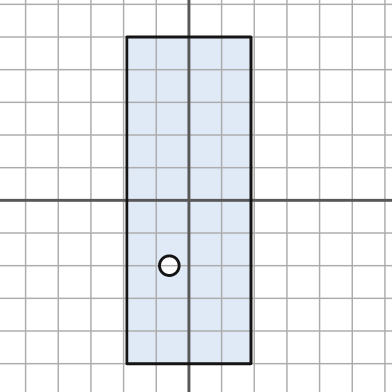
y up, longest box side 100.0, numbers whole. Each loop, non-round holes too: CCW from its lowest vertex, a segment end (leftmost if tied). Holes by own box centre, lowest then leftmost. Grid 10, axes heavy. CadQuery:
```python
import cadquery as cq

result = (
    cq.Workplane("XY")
    .moveTo(-19.0, -50.0)
    .lineTo(19.0, -50.0)
    .lineTo(19.0, 50.0)
    .lineTo(-19.0, 50.0)
    .close()
    .moveTo(-6.0, -20.0)
    .circle(3.0)
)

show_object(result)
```